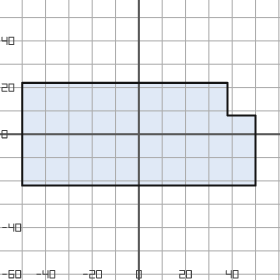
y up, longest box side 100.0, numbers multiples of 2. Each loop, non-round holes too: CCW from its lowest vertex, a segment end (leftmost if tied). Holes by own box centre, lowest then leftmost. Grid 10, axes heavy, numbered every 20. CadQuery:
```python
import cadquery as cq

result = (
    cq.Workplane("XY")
    .moveTo(-50.0, -22.0)
    .lineTo(50.0, -22.0)
    .lineTo(50.0, 8.0)
    .lineTo(38.0, 8.0)
    .lineTo(38.0, 22.0)
    .lineTo(-50.0, 22.0)
    .close()
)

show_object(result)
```